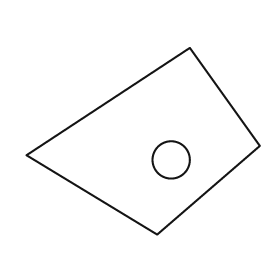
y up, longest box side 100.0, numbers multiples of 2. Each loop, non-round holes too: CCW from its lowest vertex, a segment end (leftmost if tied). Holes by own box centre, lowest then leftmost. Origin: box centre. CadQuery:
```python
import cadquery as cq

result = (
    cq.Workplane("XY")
    .moveTo(6.0, -40.0)
    .lineTo(50.0, -2.0)
    .lineTo(20.0, 40.0)
    .lineTo(-50.0, -6.0)
    .close()
    .moveTo(12.0, -8.0)
    .circle(8.0)
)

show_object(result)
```